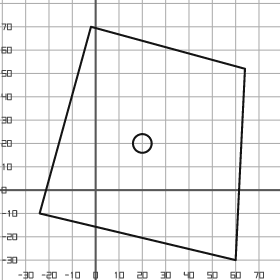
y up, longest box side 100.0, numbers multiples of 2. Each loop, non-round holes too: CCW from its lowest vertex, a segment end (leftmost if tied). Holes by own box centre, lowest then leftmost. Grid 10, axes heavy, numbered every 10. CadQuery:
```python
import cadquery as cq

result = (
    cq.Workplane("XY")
    .moveTo(60.0, -30.0)
    .lineTo(64.0, 52.0)
    .lineTo(-2.0, 70.0)
    .lineTo(-24.0, -10.0)
    .close()
    .moveTo(20.0, 20.0)
    .circle(4.0)
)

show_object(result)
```